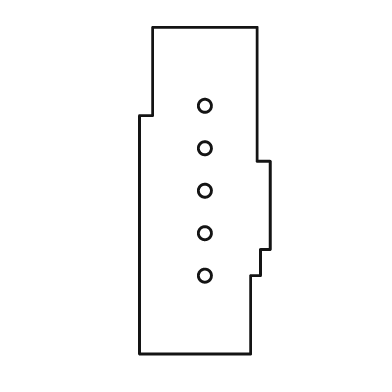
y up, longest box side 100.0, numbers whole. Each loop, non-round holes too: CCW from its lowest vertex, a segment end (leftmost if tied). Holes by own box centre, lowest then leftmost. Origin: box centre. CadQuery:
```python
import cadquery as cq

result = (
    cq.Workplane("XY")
    .moveTo(-20.0, -50.0)
    .lineTo(14.0, -50.0)
    .lineTo(14.0, -26.0)
    .lineTo(17.0, -26.0)
    .lineTo(17.0, -18.0)
    .lineTo(20.0, -18.0)
    .lineTo(20.0, 9.0)
    .lineTo(16.0, 9.0)
    .lineTo(16.0, 50.0)
    .lineTo(-16.0, 50.0)
    .lineTo(-16.0, 23.0)
    .lineTo(-20.0, 23.0)
    .close()
    .moveTo(0.0, -26.0)
    .circle(2.0)
    .moveTo(0.0, -13.0)
    .circle(2.0)
    .moveTo(0.0, 0.0)
    .circle(2.0)
    .moveTo(0.0, 13.0)
    .circle(2.0)
    .moveTo(0.0, 26.0)
    .circle(2.0)
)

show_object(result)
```